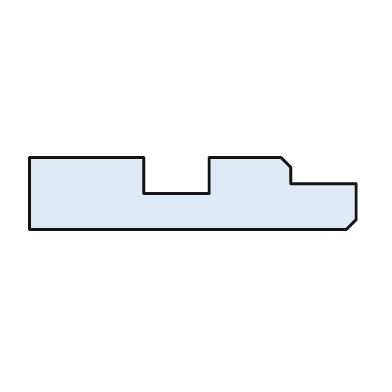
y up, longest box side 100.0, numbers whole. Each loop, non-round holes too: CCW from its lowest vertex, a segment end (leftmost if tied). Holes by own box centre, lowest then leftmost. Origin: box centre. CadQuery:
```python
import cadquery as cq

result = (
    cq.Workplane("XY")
    .moveTo(-50.0, -11.0)
    .lineTo(47.0, -11.0)
    .lineTo(50.0, -8.0)
    .lineTo(50.0, 3.0)
    .lineTo(30.0, 3.0)
    .lineTo(30.0, 8.0)
    .lineTo(27.0, 11.0)
    .lineTo(5.0, 11.0)
    .lineTo(5.0, 0.0)
    .lineTo(-15.0, 0.0)
    .lineTo(-15.0, 11.0)
    .lineTo(-50.0, 11.0)
    .close()
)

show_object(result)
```